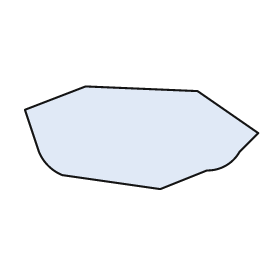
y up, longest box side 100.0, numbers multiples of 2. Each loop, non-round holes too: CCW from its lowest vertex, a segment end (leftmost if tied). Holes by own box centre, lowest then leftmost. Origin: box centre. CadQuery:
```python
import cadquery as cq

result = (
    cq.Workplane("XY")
    .moveTo(8.0, -22.0)
    .lineTo(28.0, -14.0)
    .threePointArc((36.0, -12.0), (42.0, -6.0))
    .lineTo(50.0, 2.0)
    .lineTo(24.0, 20.0)
    .lineTo(-24.0, 22.0)
    .lineTo(-50.0, 12.0)
    .lineTo(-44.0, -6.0)
    .threePointArc((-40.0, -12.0), (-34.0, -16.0))
    .close()
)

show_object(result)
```